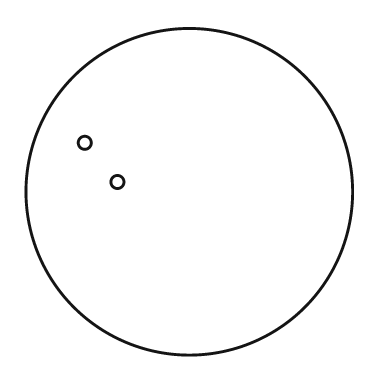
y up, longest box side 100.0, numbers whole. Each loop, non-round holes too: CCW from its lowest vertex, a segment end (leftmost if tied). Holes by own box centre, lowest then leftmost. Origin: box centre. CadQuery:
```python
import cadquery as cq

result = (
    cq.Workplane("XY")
    .moveTo(0.0, 0.0)
    .circle(50.0)
    .moveTo(-22.0, 3.0)
    .circle(2.0)
    .moveTo(-32.0, 15.0)
    .circle(2.0)
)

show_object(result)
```